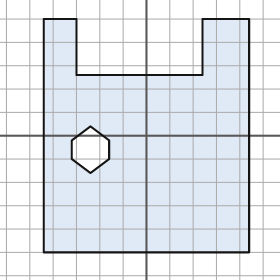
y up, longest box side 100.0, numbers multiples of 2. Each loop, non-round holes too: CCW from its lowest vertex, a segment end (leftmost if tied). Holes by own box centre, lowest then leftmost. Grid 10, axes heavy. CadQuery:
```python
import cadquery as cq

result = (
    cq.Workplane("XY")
    .moveTo(-44.0, -50.0)
    .lineTo(44.0, -50.0)
    .lineTo(44.0, 50.0)
    .lineTo(24.0, 50.0)
    .lineTo(24.0, 26.0)
    .lineTo(-30.0, 26.0)
    .lineTo(-30.0, 50.0)
    .lineTo(-44.0, 50.0)
    .close()
    .moveTo(-24.0, -16.0)
    .lineTo(-16.0, -10.0)
    .lineTo(-16.0, -2.0)
    .lineTo(-24.0, 4.0)
    .lineTo(-32.0, -2.0)
    .lineTo(-32.0, -10.0)
    .close()
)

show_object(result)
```